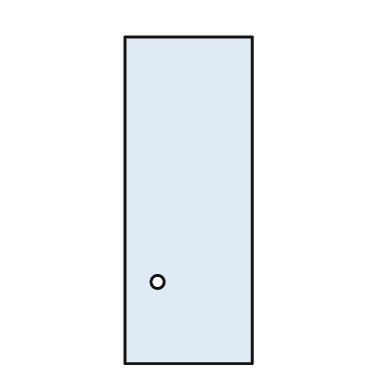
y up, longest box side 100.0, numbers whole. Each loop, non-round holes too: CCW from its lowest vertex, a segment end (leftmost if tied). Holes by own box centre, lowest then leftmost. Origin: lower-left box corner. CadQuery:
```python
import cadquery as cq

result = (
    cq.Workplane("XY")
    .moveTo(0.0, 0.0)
    .lineTo(39.0, 0.0)
    .lineTo(39.0, 100.0)
    .lineTo(0.0, 100.0)
    .close()
    .moveTo(10.0, 25.0)
    .circle(2.0)
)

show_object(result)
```